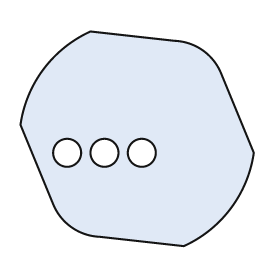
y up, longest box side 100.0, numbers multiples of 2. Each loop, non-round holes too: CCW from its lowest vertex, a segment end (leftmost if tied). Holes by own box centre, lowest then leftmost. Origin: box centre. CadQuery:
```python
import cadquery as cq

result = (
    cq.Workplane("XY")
    .moveTo(20.0, -46.0)
    .threePointArc((40.0, -30.0), (50.0, -6.0))
    .lineTo(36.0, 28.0)
    .threePointArc((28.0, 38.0), (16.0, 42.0))
    .lineTo(-20.0, 46.0)
    .threePointArc((-40.0, 30.0), (-50.0, 6.0))
    .lineTo(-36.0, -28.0)
    .threePointArc((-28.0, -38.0), (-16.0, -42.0))
    .close()
    .moveTo(-30.0, -6.0)
    .circle(6.0)
    .moveTo(-14.0, -6.0)
    .circle(6.0)
    .moveTo(2.0, -6.0)
    .circle(6.0)
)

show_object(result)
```